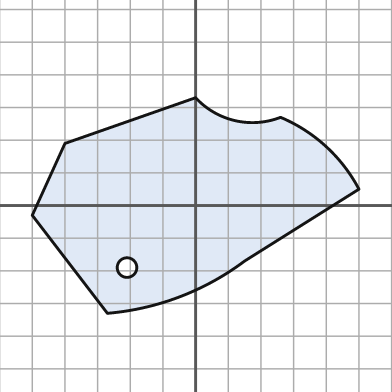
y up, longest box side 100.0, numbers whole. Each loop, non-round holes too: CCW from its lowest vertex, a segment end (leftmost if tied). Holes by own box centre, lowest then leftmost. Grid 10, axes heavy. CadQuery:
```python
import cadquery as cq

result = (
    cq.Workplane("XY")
    .moveTo(-27.0, -33.0)
    .threePointArc((-5.0, -28.0), (15.0, -17.0))
    .lineTo(50.0, 5.0)
    .threePointArc((40.0, 18.0), (26.0, 27.0))
    .threePointArc((12.0, 26.0), (0.0, 33.0))
    .lineTo(-40.0, 19.0)
    .lineTo(-50.0, -3.0)
    .close()
    .moveTo(-21.0, -19.0)
    .circle(3.0)
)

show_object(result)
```